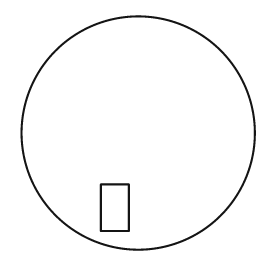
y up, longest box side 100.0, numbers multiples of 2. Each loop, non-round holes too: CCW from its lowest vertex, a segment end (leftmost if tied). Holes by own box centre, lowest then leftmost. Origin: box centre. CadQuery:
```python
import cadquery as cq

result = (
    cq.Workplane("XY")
    .moveTo(0.0, 0.0)
    .circle(50.0)
    .moveTo(-16.0, -42.0)
    .lineTo(-4.0, -42.0)
    .lineTo(-4.0, -22.0)
    .lineTo(-16.0, -22.0)
    .close()
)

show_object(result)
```